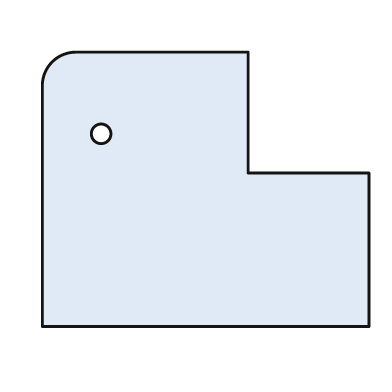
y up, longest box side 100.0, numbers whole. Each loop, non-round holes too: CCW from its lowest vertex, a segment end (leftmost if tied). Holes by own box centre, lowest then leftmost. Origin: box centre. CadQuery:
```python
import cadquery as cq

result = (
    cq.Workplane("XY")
    .moveTo(-50.0, -42.0)
    .lineTo(50.0, -42.0)
    .lineTo(50.0, 5.0)
    .lineTo(13.0, 5.0)
    .lineTo(13.0, 42.0)
    .lineTo(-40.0, 42.0)
    .threePointArc((-47.0, 39.0), (-50.0, 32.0))
    .close()
    .moveTo(-32.0, 17.0)
    .circle(3.0)
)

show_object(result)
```